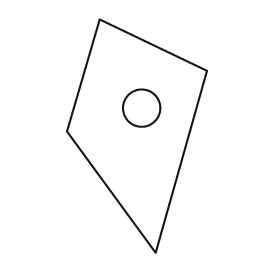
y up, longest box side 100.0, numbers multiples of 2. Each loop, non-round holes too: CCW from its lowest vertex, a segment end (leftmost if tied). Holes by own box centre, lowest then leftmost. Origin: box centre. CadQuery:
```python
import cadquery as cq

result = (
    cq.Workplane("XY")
    .moveTo(8.0, -50.0)
    .lineTo(30.0, 28.0)
    .lineTo(-16.0, 50.0)
    .lineTo(-30.0, 2.0)
    .close()
    .moveTo(2.0, 12.0)
    .circle(8.0)
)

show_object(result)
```